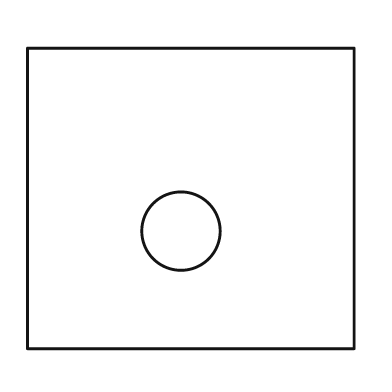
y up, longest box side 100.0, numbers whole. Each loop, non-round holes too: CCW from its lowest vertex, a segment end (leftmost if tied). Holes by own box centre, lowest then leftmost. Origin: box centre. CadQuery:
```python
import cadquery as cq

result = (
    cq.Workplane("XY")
    .moveTo(-50.0, -46.0)
    .lineTo(50.0, -46.0)
    .lineTo(50.0, 46.0)
    .lineTo(-50.0, 46.0)
    .close()
    .moveTo(-3.0, -10.0)
    .circle(12.0)
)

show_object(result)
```